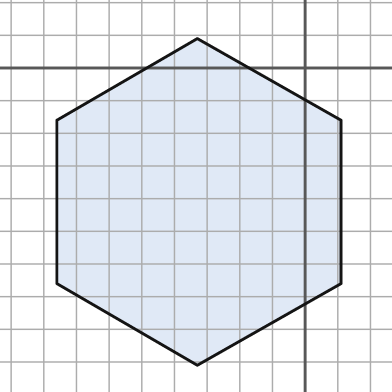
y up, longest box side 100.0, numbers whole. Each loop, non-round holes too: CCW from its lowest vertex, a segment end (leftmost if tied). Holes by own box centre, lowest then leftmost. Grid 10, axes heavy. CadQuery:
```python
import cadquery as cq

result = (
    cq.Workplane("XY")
    .moveTo(-33.0, -91.0)
    .lineTo(11.0, -66.0)
    .lineTo(11.0, -16.0)
    .lineTo(-33.0, 9.0)
    .lineTo(-76.0, -16.0)
    .lineTo(-76.0, -66.0)
    .close()
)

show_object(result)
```